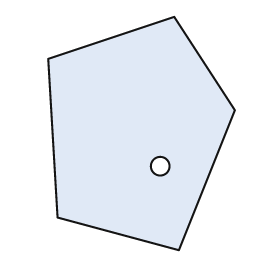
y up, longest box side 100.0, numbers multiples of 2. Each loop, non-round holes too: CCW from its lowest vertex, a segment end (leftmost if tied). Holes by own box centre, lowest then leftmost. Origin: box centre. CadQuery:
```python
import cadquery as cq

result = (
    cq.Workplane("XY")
    .moveTo(16.0, -50.0)
    .lineTo(40.0, 10.0)
    .lineTo(14.0, 50.0)
    .lineTo(-40.0, 32.0)
    .lineTo(-36.0, -36.0)
    .close()
    .moveTo(8.0, -14.0)
    .circle(4.0)
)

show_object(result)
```